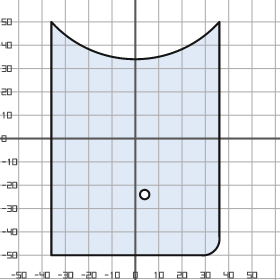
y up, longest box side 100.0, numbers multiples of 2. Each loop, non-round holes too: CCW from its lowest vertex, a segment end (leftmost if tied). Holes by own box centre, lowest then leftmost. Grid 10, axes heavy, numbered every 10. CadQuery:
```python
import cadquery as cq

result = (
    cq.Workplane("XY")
    .moveTo(-36.0, -50.0)
    .lineTo(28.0, -50.0)
    .threePointArc((34.0, -48.0), (36.0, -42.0))
    .lineTo(36.0, 50.0)
    .threePointArc((0.0, 34.0), (-36.0, 50.0))
    .close()
    .moveTo(4.0, -24.0)
    .circle(2.0)
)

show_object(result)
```